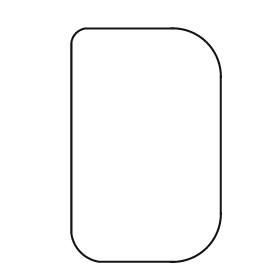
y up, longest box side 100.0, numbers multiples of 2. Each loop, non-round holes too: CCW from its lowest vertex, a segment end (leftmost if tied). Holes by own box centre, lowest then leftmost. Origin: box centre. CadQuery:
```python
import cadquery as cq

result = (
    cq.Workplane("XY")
    .moveTo(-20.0, -50.0)
    .lineTo(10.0, -50.0)
    .threePointArc((26.0, -44.0), (32.0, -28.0))
    .lineTo(32.0, 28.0)
    .threePointArc((26.0, 44.0), (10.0, 50.0))
    .lineTo(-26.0, 50.0)
    .threePointArc((-30.0, 48.0), (-32.0, 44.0))
    .lineTo(-32.0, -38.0)
    .threePointArc((-28.0, -46.0), (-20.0, -50.0))
    .close()
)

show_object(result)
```